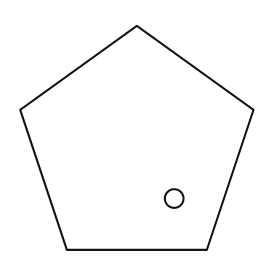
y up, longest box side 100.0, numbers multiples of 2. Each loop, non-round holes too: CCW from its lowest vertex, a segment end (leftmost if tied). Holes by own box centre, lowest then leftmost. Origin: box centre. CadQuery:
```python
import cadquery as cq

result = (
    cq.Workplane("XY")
    .moveTo(-30.0, -48.0)
    .lineTo(30.0, -48.0)
    .lineTo(50.0, 12.0)
    .lineTo(0.0, 48.0)
    .lineTo(-50.0, 12.0)
    .close()
    .moveTo(16.0, -26.0)
    .circle(4.0)
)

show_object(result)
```